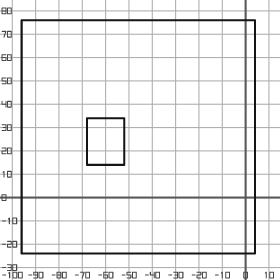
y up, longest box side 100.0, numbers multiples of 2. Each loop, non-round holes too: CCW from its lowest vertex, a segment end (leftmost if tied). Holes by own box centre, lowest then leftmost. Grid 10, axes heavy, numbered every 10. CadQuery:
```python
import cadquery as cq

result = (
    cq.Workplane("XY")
    .moveTo(-96.0, -24.0)
    .lineTo(4.0, -24.0)
    .lineTo(4.0, 76.0)
    .lineTo(-96.0, 76.0)
    .close()
    .moveTo(-68.0, 14.0)
    .lineTo(-52.0, 14.0)
    .lineTo(-52.0, 34.0)
    .lineTo(-68.0, 34.0)
    .close()
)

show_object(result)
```